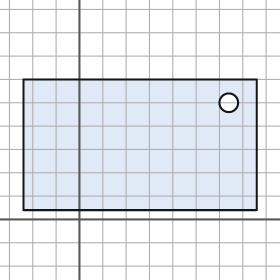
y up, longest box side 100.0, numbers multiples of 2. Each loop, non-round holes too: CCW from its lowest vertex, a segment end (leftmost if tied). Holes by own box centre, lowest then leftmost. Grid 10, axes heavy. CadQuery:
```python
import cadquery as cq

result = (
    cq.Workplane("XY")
    .moveTo(-24.0, 4.0)
    .lineTo(76.0, 4.0)
    .lineTo(76.0, 60.0)
    .lineTo(-24.0, 60.0)
    .close()
    .moveTo(64.0, 50.0)
    .circle(4.0)
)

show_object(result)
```